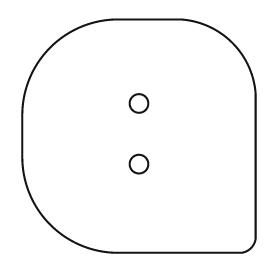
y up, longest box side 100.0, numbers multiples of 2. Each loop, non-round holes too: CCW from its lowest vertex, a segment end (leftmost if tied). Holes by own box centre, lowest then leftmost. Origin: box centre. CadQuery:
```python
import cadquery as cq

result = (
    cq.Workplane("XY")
    .moveTo(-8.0, -50.0)
    .lineTo(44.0, -50.0)
    .threePointArc((48.0, -48.0), (50.0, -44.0))
    .lineTo(50.0, 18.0)
    .threePointArc((40.0, 40.0), (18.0, 50.0))
    .lineTo(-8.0, 50.0)
    .threePointArc((-38.0, 38.0), (-50.0, 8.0))
    .lineTo(-50.0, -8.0)
    .threePointArc((-38.0, -38.0), (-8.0, -50.0))
    .close()
    .moveTo(0.0, -12.0)
    .circle(4.0)
    .moveTo(0.0, 14.0)
    .circle(4.0)
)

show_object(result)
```